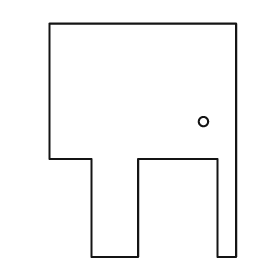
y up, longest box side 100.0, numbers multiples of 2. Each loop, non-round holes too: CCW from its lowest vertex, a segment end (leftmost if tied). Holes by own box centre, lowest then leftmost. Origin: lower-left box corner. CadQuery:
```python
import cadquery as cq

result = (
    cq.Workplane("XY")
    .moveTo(18.0, 0.0)
    .lineTo(38.0, 0.0)
    .lineTo(38.0, 42.0)
    .lineTo(72.0, 42.0)
    .lineTo(72.0, 0.0)
    .lineTo(80.0, 0.0)
    .lineTo(80.0, 100.0)
    .lineTo(0.0, 100.0)
    .lineTo(0.0, 42.0)
    .lineTo(18.0, 42.0)
    .close()
    .moveTo(66.0, 58.0)
    .circle(2.0)
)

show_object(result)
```